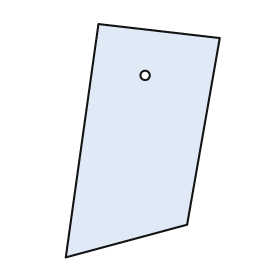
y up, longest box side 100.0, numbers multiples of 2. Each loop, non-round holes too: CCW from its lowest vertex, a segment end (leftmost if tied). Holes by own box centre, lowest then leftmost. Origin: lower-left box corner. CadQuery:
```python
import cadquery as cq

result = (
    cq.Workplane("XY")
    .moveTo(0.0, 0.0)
    .lineTo(52.0, 14.0)
    .lineTo(66.0, 94.0)
    .lineTo(14.0, 100.0)
    .close()
    .moveTo(34.0, 78.0)
    .circle(2.0)
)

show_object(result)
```